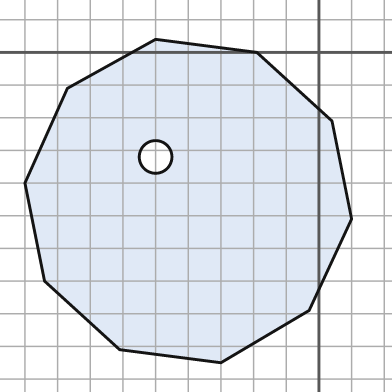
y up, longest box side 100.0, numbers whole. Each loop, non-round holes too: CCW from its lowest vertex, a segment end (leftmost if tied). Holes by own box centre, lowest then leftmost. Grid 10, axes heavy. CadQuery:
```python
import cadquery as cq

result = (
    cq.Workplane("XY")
    .moveTo(-30.0, -95.0)
    .lineTo(-3.0, -79.0)
    .lineTo(10.0, -51.0)
    .lineTo(4.0, -21.0)
    .lineTo(-19.0, 0.0)
    .lineTo(-50.0, 4.0)
    .lineTo(-77.0, -11.0)
    .lineTo(-90.0, -40.0)
    .lineTo(-84.0, -70.0)
    .lineTo(-61.0, -91.0)
    .close()
    .moveTo(-50.0, -32.0)
    .circle(5.0)
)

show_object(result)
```